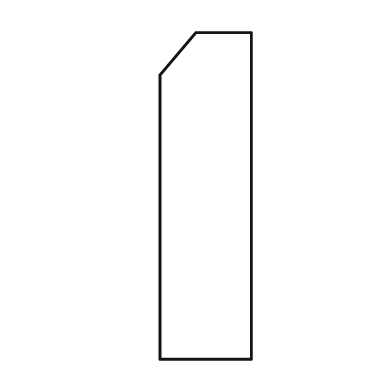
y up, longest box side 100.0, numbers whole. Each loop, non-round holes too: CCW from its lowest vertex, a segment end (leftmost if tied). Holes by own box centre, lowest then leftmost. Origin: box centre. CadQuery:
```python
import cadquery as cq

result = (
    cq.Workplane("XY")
    .moveTo(-14.0, -50.0)
    .lineTo(14.0, -50.0)
    .lineTo(14.0, 50.0)
    .lineTo(-3.0, 50.0)
    .lineTo(-14.0, 37.0)
    .close()
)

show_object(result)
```